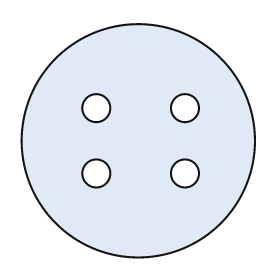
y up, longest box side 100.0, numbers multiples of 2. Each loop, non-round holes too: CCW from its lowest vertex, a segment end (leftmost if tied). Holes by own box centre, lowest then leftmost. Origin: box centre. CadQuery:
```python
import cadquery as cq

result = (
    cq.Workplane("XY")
    .moveTo(0.0, 0.0)
    .circle(50.0)
    .moveTo(-18.0, -14.0)
    .circle(6.0)
    .moveTo(20.0, -14.0)
    .circle(6.0)
    .moveTo(-18.0, 14.0)
    .circle(6.0)
    .moveTo(20.0, 14.0)
    .circle(6.0)
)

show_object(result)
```